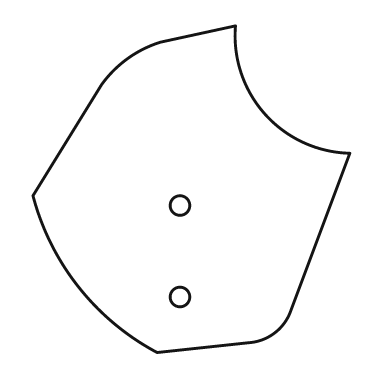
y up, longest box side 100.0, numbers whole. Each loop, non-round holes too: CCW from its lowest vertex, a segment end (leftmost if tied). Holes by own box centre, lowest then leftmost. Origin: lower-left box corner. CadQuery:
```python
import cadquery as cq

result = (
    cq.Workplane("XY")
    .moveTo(38.0, 0.0)
    .lineTo(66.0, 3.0)
    .threePointArc((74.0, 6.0), (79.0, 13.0))
    .lineTo(97.0, 61.0)
    .threePointArc((71.0, 73.0), (62.0, 100.0))
    .lineTo(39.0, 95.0)
    .threePointArc((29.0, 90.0), (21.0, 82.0))
    .lineTo(0.0, 48.0)
    .threePointArc((14.0, 20.0), (38.0, 0.0))
    .close()
    .moveTo(45.0, 17.0)
    .circle(3.0)
    .moveTo(45.0, 45.0)
    .circle(3.0)
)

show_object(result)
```